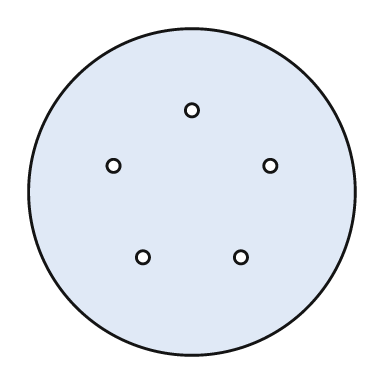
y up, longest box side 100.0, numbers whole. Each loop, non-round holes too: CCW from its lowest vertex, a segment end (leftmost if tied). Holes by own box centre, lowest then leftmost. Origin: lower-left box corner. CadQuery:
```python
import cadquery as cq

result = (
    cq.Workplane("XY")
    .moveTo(50.0, 50.0)
    .circle(50.0)
    .moveTo(35.0, 30.0)
    .circle(2.0)
    .moveTo(65.0, 30.0)
    .circle(2.0)
    .moveTo(26.0, 58.0)
    .circle(2.0)
    .moveTo(74.0, 58.0)
    .circle(2.0)
    .moveTo(50.0, 75.0)
    .circle(2.0)
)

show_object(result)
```